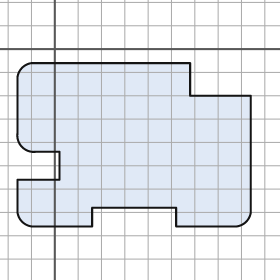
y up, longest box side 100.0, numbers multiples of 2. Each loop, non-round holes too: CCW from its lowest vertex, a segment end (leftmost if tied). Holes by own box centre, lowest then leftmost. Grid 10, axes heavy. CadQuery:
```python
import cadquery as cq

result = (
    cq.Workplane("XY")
    .moveTo(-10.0, -76.0)
    .lineTo(16.0, -76.0)
    .lineTo(16.0, -68.0)
    .lineTo(52.0, -68.0)
    .lineTo(52.0, -76.0)
    .lineTo(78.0, -76.0)
    .threePointArc((82.0, -74.0), (84.0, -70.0))
    .lineTo(84.0, -20.0)
    .lineTo(58.0, -20.0)
    .lineTo(58.0, -6.0)
    .lineTo(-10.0, -6.0)
    .threePointArc((-14.0, -8.0), (-16.0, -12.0))
    .lineTo(-16.0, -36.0)
    .threePointArc((-14.0, -42.0), (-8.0, -44.0))
    .lineTo(2.0, -44.0)
    .lineTo(2.0, -56.0)
    .lineTo(-16.0, -56.0)
    .lineTo(-16.0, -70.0)
    .threePointArc((-14.0, -74.0), (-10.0, -76.0))
    .close()
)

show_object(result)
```